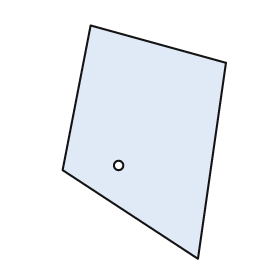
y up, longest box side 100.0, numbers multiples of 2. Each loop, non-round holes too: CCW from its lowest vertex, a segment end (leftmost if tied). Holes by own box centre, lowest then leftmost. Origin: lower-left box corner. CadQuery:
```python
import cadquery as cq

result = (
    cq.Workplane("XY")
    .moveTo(58.0, 0.0)
    .lineTo(70.0, 84.0)
    .lineTo(12.0, 100.0)
    .lineTo(0.0, 38.0)
    .close()
    .moveTo(24.0, 40.0)
    .circle(2.0)
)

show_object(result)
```